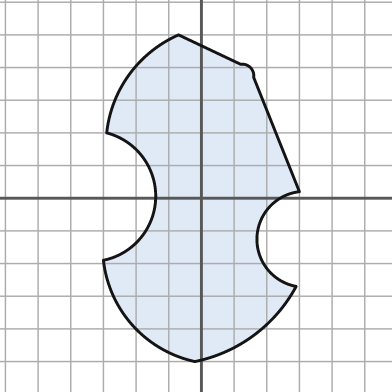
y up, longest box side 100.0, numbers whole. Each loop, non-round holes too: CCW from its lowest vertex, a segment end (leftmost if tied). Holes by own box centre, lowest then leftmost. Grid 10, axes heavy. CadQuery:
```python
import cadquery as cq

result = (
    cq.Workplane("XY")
    .moveTo(-2.0, -50.0)
    .threePointArc((16.0, -42.0), (29.0, -27.0))
    .threePointArc((17.0, -12.0), (30.0, 2.0))
    .lineTo(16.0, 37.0)
    .threePointArc((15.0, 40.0), (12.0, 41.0))
    .lineTo(-7.0, 50.0)
    .threePointArc((-22.0, 38.0), (-29.0, 20.0))
    .threePointArc((-14.0, 0.0), (-30.0, -19.0))
    .threePointArc((-21.0, -39.0), (-2.0, -50.0))
    .close()
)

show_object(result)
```